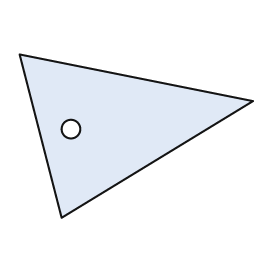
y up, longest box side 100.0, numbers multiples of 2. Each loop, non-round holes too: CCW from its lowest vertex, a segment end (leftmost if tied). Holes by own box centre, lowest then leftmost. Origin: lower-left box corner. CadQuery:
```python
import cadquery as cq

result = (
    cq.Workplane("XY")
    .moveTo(18.0, 0.0)
    .lineTo(100.0, 50.0)
    .lineTo(0.0, 70.0)
    .close()
    .moveTo(22.0, 38.0)
    .circle(4.0)
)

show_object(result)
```